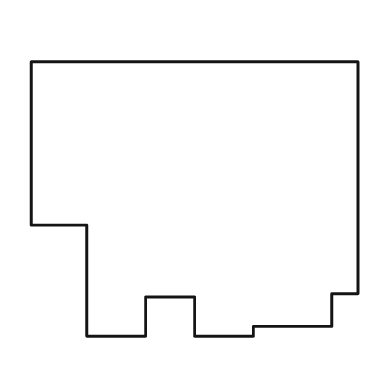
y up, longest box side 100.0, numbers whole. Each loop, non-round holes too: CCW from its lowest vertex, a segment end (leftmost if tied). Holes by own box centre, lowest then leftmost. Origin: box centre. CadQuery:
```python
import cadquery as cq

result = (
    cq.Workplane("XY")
    .moveTo(-33.0, -42.0)
    .lineTo(-15.0, -42.0)
    .lineTo(-15.0, -30.0)
    .lineTo(0.0, -30.0)
    .lineTo(0.0, -42.0)
    .lineTo(18.0, -42.0)
    .lineTo(18.0, -39.0)
    .lineTo(42.0, -39.0)
    .lineTo(42.0, -29.0)
    .lineTo(50.0, -29.0)
    .lineTo(50.0, 42.0)
    .lineTo(-50.0, 42.0)
    .lineTo(-50.0, -8.0)
    .lineTo(-33.0, -8.0)
    .close()
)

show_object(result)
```